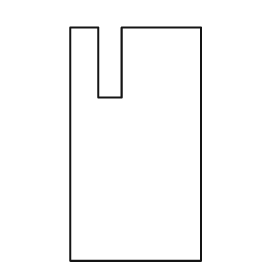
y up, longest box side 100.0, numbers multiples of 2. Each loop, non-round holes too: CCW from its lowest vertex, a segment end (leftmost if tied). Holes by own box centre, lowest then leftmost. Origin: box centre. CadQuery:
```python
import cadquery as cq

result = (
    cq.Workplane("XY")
    .moveTo(-28.0, -50.0)
    .lineTo(28.0, -50.0)
    .lineTo(28.0, 50.0)
    .lineTo(-6.0, 50.0)
    .lineTo(-6.0, 20.0)
    .lineTo(-16.0, 20.0)
    .lineTo(-16.0, 50.0)
    .lineTo(-28.0, 50.0)
    .close()
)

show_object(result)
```